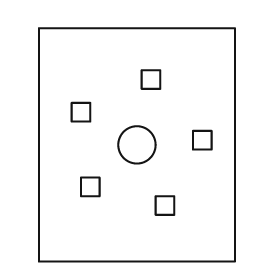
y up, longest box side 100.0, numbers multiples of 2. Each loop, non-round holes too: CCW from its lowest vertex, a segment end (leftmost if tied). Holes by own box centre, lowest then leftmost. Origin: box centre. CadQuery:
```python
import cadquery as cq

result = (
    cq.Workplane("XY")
    .moveTo(-42.0, -50.0)
    .lineTo(42.0, -50.0)
    .lineTo(42.0, 50.0)
    .lineTo(-42.0, 50.0)
    .close()
    .moveTo(8.0, -30.0)
    .lineTo(16.0, -30.0)
    .lineTo(16.0, -22.0)
    .lineTo(8.0, -22.0)
    .close()
    .moveTo(-24.0, -22.0)
    .lineTo(-16.0, -22.0)
    .lineTo(-16.0, -14.0)
    .lineTo(-24.0, -14.0)
    .close()
    .moveTo(0.0, 0.0)
    .circle(8.0)
    .moveTo(24.0, -2.0)
    .lineTo(32.0, -2.0)
    .lineTo(32.0, 6.0)
    .lineTo(24.0, 6.0)
    .close()
    .moveTo(-28.0, 10.0)
    .lineTo(-20.0, 10.0)
    .lineTo(-20.0, 18.0)
    .lineTo(-28.0, 18.0)
    .close()
    .moveTo(2.0, 24.0)
    .lineTo(10.0, 24.0)
    .lineTo(10.0, 32.0)
    .lineTo(2.0, 32.0)
    .close()
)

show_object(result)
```